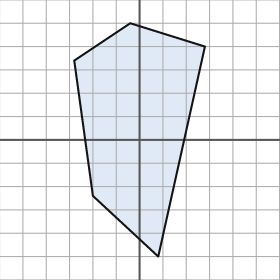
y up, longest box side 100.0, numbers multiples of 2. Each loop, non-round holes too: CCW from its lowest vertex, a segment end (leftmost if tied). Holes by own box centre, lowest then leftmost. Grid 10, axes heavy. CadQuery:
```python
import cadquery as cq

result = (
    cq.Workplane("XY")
    .moveTo(8.0, -50.0)
    .lineTo(28.0, 40.0)
    .lineTo(-4.0, 50.0)
    .lineTo(-28.0, 34.0)
    .lineTo(-20.0, -24.0)
    .close()
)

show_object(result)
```